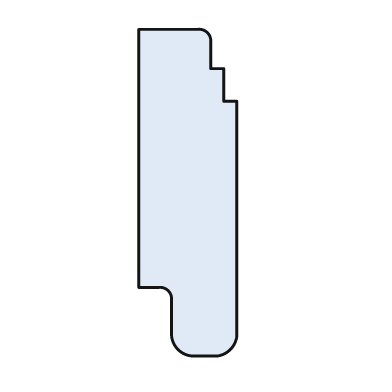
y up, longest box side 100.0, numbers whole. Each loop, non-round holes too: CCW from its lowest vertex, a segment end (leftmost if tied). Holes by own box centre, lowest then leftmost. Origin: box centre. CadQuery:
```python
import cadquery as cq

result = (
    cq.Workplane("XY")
    .moveTo(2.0, -50.0)
    .lineTo(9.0, -50.0)
    .threePointArc((13.0, -48.0), (15.0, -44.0))
    .lineTo(15.0, 28.0)
    .lineTo(11.0, 28.0)
    .lineTo(11.0, 38.0)
    .lineTo(7.0, 38.0)
    .lineTo(7.0, 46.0)
    .threePointArc((6.0, 49.0), (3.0, 50.0))
    .lineTo(-15.0, 50.0)
    .lineTo(-15.0, -29.0)
    .lineTo(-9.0, -29.0)
    .threePointArc((-6.0, -30.0), (-5.0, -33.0))
    .lineTo(-5.0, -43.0)
    .threePointArc((-3.0, -48.0), (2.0, -50.0))
    .close()
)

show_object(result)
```